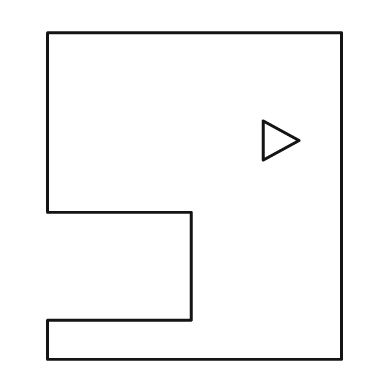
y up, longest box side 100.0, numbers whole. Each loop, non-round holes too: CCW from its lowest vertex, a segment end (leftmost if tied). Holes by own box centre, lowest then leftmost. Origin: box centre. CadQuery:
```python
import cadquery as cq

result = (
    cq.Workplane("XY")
    .moveTo(-45.0, -50.0)
    .lineTo(45.0, -50.0)
    .lineTo(45.0, 50.0)
    .lineTo(-45.0, 50.0)
    .lineTo(-45.0, -5.0)
    .lineTo(-1.0, -5.0)
    .lineTo(-1.0, -38.0)
    .lineTo(-45.0, -38.0)
    .close()
    .moveTo(21.0, 11.0)
    .lineTo(32.0, 17.0)
    .lineTo(21.0, 23.0)
    .close()
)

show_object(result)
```